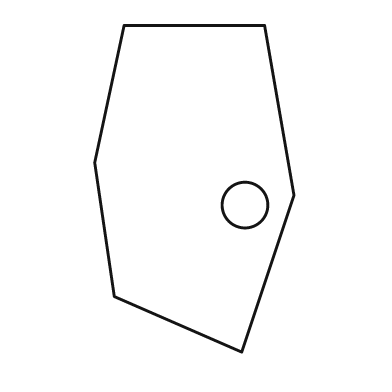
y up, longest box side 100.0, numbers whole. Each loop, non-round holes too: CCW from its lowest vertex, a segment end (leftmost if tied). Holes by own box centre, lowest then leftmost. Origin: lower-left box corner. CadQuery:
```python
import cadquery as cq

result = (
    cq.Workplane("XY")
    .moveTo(45.0, 0.0)
    .lineTo(61.0, 48.0)
    .lineTo(52.0, 100.0)
    .lineTo(9.0, 100.0)
    .lineTo(0.0, 58.0)
    .lineTo(6.0, 17.0)
    .close()
    .moveTo(46.0, 45.0)
    .circle(7.0)
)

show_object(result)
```